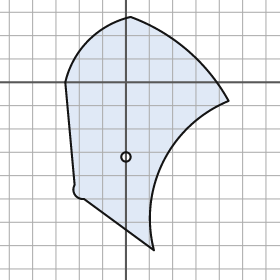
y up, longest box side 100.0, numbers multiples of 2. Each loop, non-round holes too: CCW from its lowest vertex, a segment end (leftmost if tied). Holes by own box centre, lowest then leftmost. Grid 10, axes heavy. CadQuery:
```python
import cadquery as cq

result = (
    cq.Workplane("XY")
    .moveTo(12.0, -72.0)
    .threePointArc((16.0, -34.0), (44.0, -8.0))
    .threePointArc((26.0, 14.0), (2.0, 28.0))
    .threePointArc((-16.0, 18.0), (-26.0, 0.0))
    .lineTo(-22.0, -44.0)
    .threePointArc((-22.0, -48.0), (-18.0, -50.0))
    .close()
    .moveTo(0.0, -32.0)
    .circle(2.0)
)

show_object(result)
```